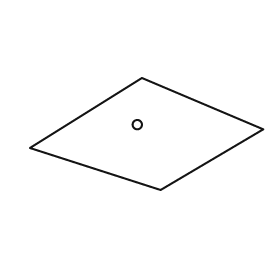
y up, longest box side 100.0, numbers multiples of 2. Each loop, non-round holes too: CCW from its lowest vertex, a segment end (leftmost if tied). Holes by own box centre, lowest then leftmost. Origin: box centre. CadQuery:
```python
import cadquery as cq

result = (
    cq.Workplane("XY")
    .moveTo(6.0, -24.0)
    .lineTo(50.0, 2.0)
    .lineTo(-2.0, 24.0)
    .lineTo(-50.0, -6.0)
    .close()
    .moveTo(-4.0, 4.0)
    .circle(2.0)
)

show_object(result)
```